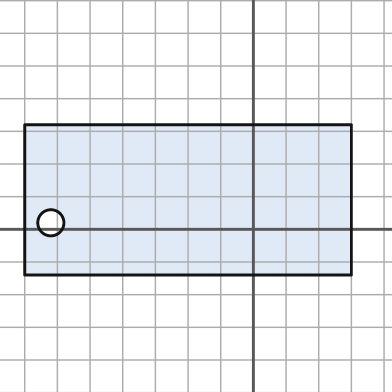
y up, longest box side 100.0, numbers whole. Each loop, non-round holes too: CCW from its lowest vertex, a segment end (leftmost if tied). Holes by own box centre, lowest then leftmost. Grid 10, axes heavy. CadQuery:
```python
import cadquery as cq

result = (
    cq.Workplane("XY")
    .moveTo(-70.0, -14.0)
    .lineTo(30.0, -14.0)
    .lineTo(30.0, 32.0)
    .lineTo(-70.0, 32.0)
    .close()
    .moveTo(-62.0, 2.0)
    .circle(4.0)
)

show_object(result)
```